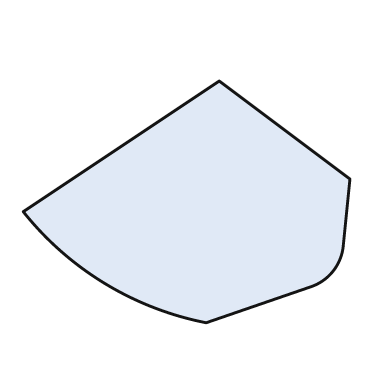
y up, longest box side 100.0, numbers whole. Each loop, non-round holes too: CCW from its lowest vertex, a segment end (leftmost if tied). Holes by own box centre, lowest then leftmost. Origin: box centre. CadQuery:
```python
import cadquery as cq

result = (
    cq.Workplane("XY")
    .moveTo(6.0, -37.0)
    .lineTo(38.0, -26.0)
    .threePointArc((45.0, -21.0), (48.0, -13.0))
    .lineTo(50.0, 7.0)
    .lineTo(10.0, 37.0)
    .lineTo(-50.0, -3.0)
    .threePointArc((-25.0, -25.0), (6.0, -37.0))
    .close()
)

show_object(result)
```